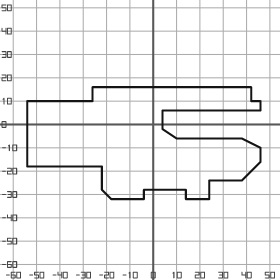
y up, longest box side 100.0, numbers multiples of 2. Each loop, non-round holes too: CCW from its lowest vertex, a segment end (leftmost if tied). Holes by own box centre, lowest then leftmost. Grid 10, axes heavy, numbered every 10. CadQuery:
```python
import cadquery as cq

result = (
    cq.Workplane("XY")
    .moveTo(-18.0, -32.0)
    .lineTo(-4.0, -32.0)
    .lineTo(-4.0, -28.0)
    .lineTo(14.0, -28.0)
    .lineTo(14.0, -32.0)
    .lineTo(24.0, -32.0)
    .lineTo(24.0, -24.0)
    .lineTo(38.0, -24.0)
    .lineTo(46.0, -16.0)
    .lineTo(46.0, -10.0)
    .lineTo(38.0, -6.0)
    .lineTo(10.0, -6.0)
    .lineTo(4.0, -2.0)
    .lineTo(4.0, 6.0)
    .lineTo(46.0, 6.0)
    .lineTo(46.0, 10.0)
    .lineTo(42.0, 10.0)
    .lineTo(42.0, 16.0)
    .lineTo(-26.0, 16.0)
    .lineTo(-26.0, 10.0)
    .lineTo(-54.0, 10.0)
    .lineTo(-54.0, -18.0)
    .lineTo(-22.0, -18.0)
    .lineTo(-22.0, -28.0)
    .close()
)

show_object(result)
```